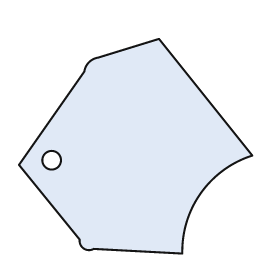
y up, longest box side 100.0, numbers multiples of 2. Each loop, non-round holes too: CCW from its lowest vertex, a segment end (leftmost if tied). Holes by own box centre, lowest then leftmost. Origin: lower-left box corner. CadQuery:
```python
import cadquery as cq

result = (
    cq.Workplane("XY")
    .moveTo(70.0, 0.0)
    .threePointArc((78.0, 26.0), (100.0, 42.0))
    .lineTo(60.0, 92.0)
    .lineTo(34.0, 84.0)
    .threePointArc((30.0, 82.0), (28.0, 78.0))
    .lineTo(0.0, 38.0)
    .lineTo(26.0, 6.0)
    .threePointArc((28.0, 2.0), (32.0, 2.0))
    .close()
    .moveTo(14.0, 40.0)
    .circle(4.0)
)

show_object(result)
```